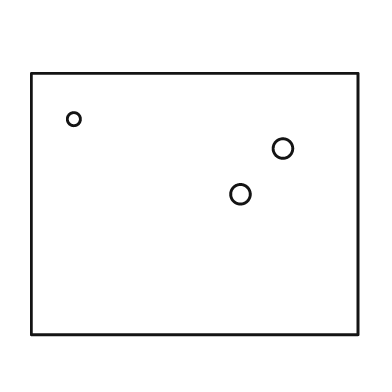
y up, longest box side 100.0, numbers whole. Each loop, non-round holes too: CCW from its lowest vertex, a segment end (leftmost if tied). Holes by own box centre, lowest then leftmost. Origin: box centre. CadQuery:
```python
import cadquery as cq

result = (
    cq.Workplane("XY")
    .moveTo(-50.0, -40.0)
    .lineTo(50.0, -40.0)
    .lineTo(50.0, 40.0)
    .lineTo(-50.0, 40.0)
    .close()
    .moveTo(14.0, 3.0)
    .circle(3.0)
    .moveTo(27.0, 17.0)
    .circle(3.0)
    .moveTo(-37.0, 26.0)
    .circle(2.0)
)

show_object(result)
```